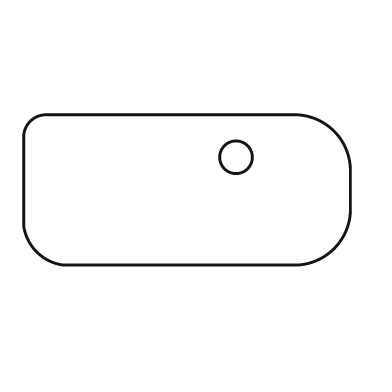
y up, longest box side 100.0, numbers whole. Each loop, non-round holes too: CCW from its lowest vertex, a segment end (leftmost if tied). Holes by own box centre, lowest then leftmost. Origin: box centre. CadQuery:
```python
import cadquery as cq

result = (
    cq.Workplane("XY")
    .moveTo(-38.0, -23.0)
    .lineTo(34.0, -23.0)
    .threePointArc((45.0, -18.0), (50.0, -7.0))
    .lineTo(50.0, 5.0)
    .threePointArc((45.0, 18.0), (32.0, 23.0))
    .lineTo(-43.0, 23.0)
    .threePointArc((-48.0, 21.0), (-50.0, 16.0))
    .lineTo(-50.0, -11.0)
    .threePointArc((-46.0, -19.0), (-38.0, -23.0))
    .close()
    .moveTo(15.0, 10.0)
    .circle(5.0)
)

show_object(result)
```